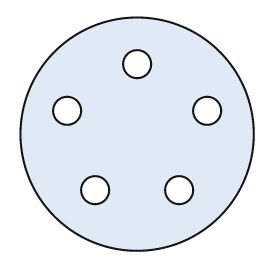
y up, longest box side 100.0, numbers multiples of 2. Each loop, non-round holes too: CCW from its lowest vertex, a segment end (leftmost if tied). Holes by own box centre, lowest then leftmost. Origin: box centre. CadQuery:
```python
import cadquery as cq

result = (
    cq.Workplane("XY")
    .moveTo(0.0, 0.0)
    .circle(50.0)
    .moveTo(-18.0, -24.0)
    .circle(6.0)
    .moveTo(18.0, -24.0)
    .circle(6.0)
    .moveTo(-30.0, 10.0)
    .circle(6.0)
    .moveTo(30.0, 10.0)
    .circle(6.0)
    .moveTo(0.0, 30.0)
    .circle(6.0)
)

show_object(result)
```